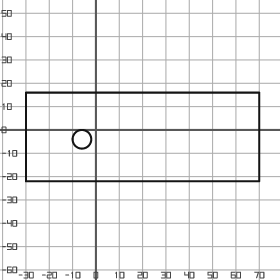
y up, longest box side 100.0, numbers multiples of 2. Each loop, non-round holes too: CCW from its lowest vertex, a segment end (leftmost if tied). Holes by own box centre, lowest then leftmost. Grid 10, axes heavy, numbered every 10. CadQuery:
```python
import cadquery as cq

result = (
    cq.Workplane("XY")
    .moveTo(-30.0, -22.0)
    .lineTo(70.0, -22.0)
    .lineTo(70.0, 16.0)
    .lineTo(-30.0, 16.0)
    .close()
    .moveTo(-6.0, -4.0)
    .circle(4.0)
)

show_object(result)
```